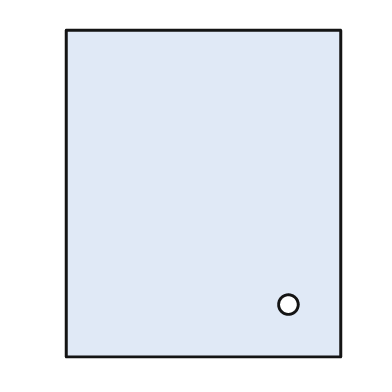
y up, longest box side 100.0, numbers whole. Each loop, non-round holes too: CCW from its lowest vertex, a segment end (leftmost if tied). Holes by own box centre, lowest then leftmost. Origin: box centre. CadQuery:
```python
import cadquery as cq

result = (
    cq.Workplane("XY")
    .moveTo(-42.0, -50.0)
    .lineTo(42.0, -50.0)
    .lineTo(42.0, 50.0)
    .lineTo(-42.0, 50.0)
    .close()
    .moveTo(26.0, -34.0)
    .circle(3.0)
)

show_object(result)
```